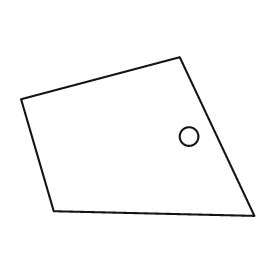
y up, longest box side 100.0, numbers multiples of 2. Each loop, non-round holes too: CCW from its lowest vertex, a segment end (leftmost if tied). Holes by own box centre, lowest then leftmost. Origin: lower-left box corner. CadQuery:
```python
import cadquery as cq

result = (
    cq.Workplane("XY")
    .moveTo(100.0, 0.0)
    .lineTo(68.0, 68.0)
    .lineTo(0.0, 50.0)
    .lineTo(14.0, 2.0)
    .close()
    .moveTo(72.0, 34.0)
    .circle(4.0)
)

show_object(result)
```